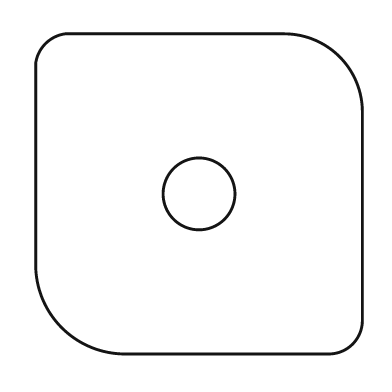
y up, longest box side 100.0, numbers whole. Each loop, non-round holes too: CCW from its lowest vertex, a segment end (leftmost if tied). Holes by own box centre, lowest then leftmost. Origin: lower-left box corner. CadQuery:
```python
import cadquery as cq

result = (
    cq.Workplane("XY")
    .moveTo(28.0, 0.0)
    .lineTo(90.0, 0.0)
    .threePointArc((97.0, 3.0), (100.0, 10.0))
    .lineTo(100.0, 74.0)
    .threePointArc((93.0, 91.0), (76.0, 98.0))
    .lineTo(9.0, 98.0)
    .threePointArc((3.0, 95.0), (0.0, 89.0))
    .lineTo(0.0, 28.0)
    .threePointArc((8.0, 8.0), (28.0, 0.0))
    .close()
    .moveTo(50.0, 49.0)
    .circle(11.0)
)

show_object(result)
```